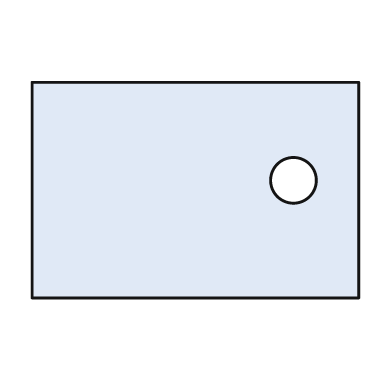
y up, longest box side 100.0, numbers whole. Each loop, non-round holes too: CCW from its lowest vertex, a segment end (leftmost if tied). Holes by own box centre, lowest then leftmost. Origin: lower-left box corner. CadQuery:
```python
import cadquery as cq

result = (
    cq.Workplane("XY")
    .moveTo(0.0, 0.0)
    .lineTo(100.0, 0.0)
    .lineTo(100.0, 66.0)
    .lineTo(0.0, 66.0)
    .close()
    .moveTo(80.0, 36.0)
    .circle(7.0)
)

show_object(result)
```